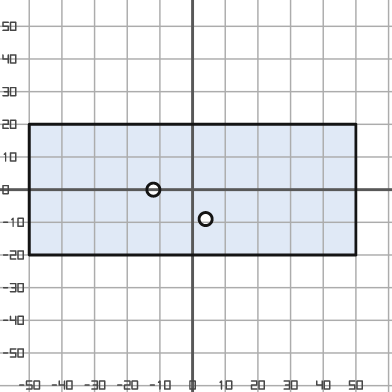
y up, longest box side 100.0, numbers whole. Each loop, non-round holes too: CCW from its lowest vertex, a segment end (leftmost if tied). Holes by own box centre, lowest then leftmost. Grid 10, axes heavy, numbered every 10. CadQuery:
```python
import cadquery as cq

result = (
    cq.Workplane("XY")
    .moveTo(-50.0, -20.0)
    .lineTo(50.0, -20.0)
    .lineTo(50.0, 20.0)
    .lineTo(-50.0, 20.0)
    .close()
    .moveTo(4.0, -9.0)
    .circle(2.0)
    .moveTo(-12.0, 0.0)
    .circle(2.0)
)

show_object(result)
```